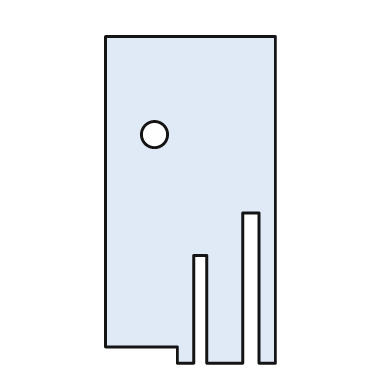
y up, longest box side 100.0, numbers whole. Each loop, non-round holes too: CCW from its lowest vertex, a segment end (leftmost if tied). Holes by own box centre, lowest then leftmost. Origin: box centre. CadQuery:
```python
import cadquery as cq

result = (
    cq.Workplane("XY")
    .moveTo(-4.0, -50.0)
    .lineTo(1.0, -50.0)
    .lineTo(1.0, -17.0)
    .lineTo(5.0, -17.0)
    .lineTo(5.0, -50.0)
    .lineTo(16.0, -50.0)
    .lineTo(16.0, -4.0)
    .lineTo(21.0, -4.0)
    .lineTo(21.0, -50.0)
    .lineTo(26.0, -50.0)
    .lineTo(26.0, 50.0)
    .lineTo(-26.0, 50.0)
    .lineTo(-26.0, -45.0)
    .lineTo(-4.0, -45.0)
    .close()
    .moveTo(-11.0, 20.0)
    .circle(4.0)
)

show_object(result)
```